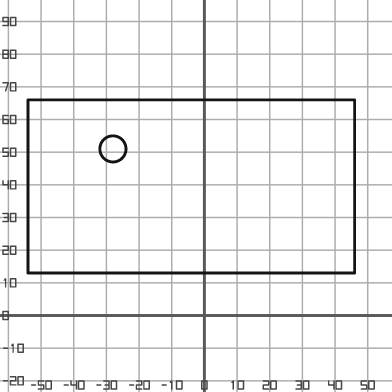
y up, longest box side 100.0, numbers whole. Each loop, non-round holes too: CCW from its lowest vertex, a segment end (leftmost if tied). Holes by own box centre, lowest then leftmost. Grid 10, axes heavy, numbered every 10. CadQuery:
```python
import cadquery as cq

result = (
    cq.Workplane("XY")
    .moveTo(-54.0, 13.0)
    .lineTo(46.0, 13.0)
    .lineTo(46.0, 66.0)
    .lineTo(-54.0, 66.0)
    .close()
    .moveTo(-28.0, 51.0)
    .circle(4.0)
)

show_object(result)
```